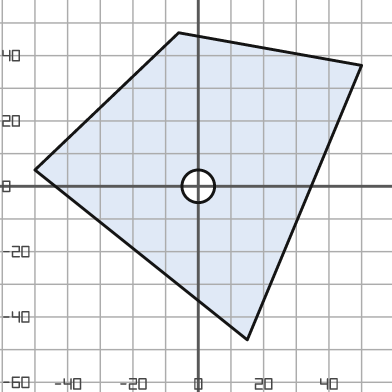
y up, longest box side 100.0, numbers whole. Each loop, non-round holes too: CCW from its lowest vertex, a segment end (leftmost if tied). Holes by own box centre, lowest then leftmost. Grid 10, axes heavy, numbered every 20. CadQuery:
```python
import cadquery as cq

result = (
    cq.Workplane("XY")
    .moveTo(15.0, -47.0)
    .lineTo(50.0, 37.0)
    .lineTo(-6.0, 47.0)
    .lineTo(-50.0, 5.0)
    .close()
    .moveTo(0.0, 0.0)
    .circle(5.0)
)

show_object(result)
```